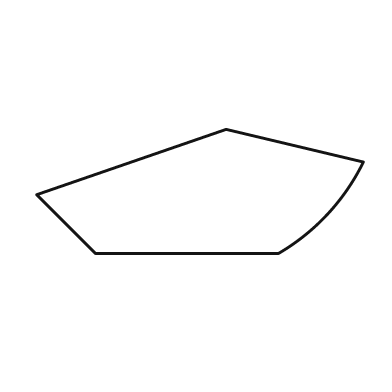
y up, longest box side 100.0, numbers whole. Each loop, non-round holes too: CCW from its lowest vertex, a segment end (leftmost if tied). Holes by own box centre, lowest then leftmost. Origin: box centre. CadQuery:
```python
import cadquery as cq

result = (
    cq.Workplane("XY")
    .moveTo(-32.0, -19.0)
    .lineTo(24.0, -19.0)
    .threePointArc((39.0, -7.0), (50.0, 9.0))
    .lineTo(8.0, 19.0)
    .lineTo(-50.0, -1.0)
    .close()
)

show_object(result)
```